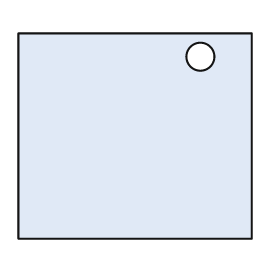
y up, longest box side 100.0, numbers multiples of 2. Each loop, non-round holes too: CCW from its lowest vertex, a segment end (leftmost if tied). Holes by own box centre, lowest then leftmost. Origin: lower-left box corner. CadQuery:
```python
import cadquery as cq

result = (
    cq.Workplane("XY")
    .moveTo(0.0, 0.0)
    .lineTo(100.0, 0.0)
    .lineTo(100.0, 88.0)
    .lineTo(0.0, 88.0)
    .close()
    .moveTo(78.0, 78.0)
    .circle(6.0)
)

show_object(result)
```